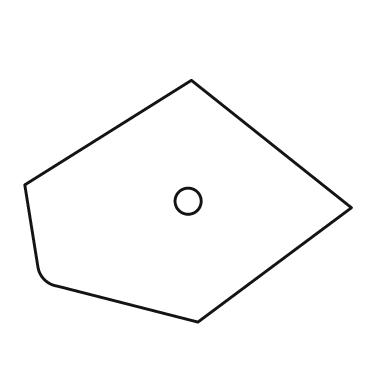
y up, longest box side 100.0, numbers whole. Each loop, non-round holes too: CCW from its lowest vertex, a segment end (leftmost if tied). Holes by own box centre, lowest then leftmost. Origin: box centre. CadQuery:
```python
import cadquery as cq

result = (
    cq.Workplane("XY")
    .moveTo(3.0, -37.0)
    .lineTo(50.0, -2.0)
    .lineTo(1.0, 37.0)
    .lineTo(-50.0, 5.0)
    .lineTo(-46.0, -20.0)
    .threePointArc((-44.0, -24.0), (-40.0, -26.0))
    .close()
    .moveTo(0.0, 0.0)
    .circle(4.0)
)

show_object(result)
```